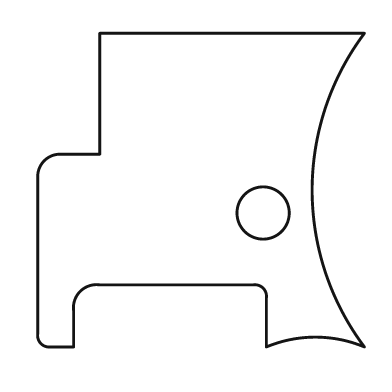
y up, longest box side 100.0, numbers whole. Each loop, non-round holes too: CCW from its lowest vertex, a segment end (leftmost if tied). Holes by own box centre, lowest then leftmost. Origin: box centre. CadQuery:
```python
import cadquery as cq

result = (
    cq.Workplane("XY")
    .moveTo(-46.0, -48.0)
    .lineTo(-39.0, -48.0)
    .lineTo(-39.0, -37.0)
    .threePointArc((-37.0, -31.0), (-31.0, -29.0))
    .lineTo(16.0, -29.0)
    .threePointArc((19.0, -30.0), (20.0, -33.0))
    .lineTo(20.0, -48.0)
    .threePointArc((35.0, -45.0), (50.0, -48.0))
    .threePointArc((34.0, 0.0), (50.0, 48.0))
    .lineTo(-31.0, 48.0)
    .lineTo(-31.0, 11.0)
    .lineTo(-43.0, 11.0)
    .threePointArc((-48.0, 9.0), (-50.0, 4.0))
    .lineTo(-50.0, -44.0)
    .threePointArc((-49.0, -47.0), (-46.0, -48.0))
    .close()
    .moveTo(19.0, -7.0)
    .circle(8.0)
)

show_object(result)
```